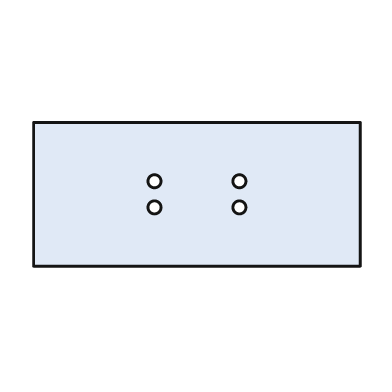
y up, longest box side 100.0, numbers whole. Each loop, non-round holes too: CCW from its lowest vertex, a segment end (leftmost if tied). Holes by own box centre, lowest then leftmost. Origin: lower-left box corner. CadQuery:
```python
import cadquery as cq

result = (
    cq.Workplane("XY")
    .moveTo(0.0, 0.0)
    .lineTo(100.0, 0.0)
    .lineTo(100.0, 44.0)
    .lineTo(0.0, 44.0)
    .close()
    .moveTo(37.0, 18.0)
    .circle(2.0)
    .moveTo(63.0, 18.0)
    .circle(2.0)
    .moveTo(37.0, 26.0)
    .circle(2.0)
    .moveTo(63.0, 26.0)
    .circle(2.0)
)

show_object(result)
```